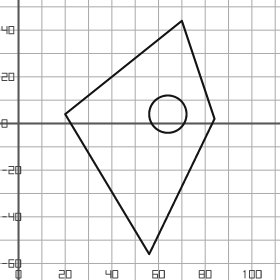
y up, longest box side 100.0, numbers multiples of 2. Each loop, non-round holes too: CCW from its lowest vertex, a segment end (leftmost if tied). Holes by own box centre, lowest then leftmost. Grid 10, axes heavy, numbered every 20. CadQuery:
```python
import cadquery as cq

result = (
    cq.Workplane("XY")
    .moveTo(56.0, -56.0)
    .lineTo(84.0, 2.0)
    .lineTo(70.0, 44.0)
    .lineTo(20.0, 4.0)
    .close()
    .moveTo(64.0, 4.0)
    .circle(8.0)
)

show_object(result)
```